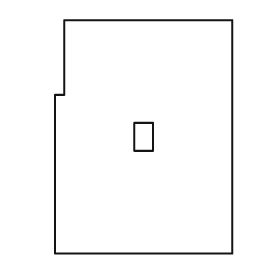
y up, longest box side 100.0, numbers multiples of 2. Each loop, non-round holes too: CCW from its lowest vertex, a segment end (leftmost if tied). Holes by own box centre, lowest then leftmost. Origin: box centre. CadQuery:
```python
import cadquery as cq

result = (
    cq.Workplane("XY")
    .moveTo(-38.0, -50.0)
    .lineTo(38.0, -50.0)
    .lineTo(38.0, 50.0)
    .lineTo(-34.0, 50.0)
    .lineTo(-34.0, 18.0)
    .lineTo(-38.0, 18.0)
    .close()
    .moveTo(-4.0, -6.0)
    .lineTo(4.0, -6.0)
    .lineTo(4.0, 6.0)
    .lineTo(-4.0, 6.0)
    .close()
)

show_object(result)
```